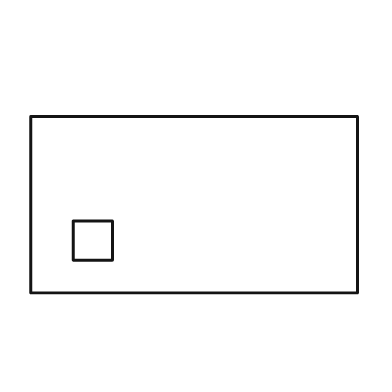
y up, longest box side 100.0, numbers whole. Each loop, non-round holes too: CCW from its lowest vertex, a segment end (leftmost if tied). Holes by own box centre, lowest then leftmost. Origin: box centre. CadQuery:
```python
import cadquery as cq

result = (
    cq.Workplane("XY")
    .moveTo(-50.0, -27.0)
    .lineTo(50.0, -27.0)
    .lineTo(50.0, 27.0)
    .lineTo(-50.0, 27.0)
    .close()
    .moveTo(-37.0, -17.0)
    .lineTo(-25.0, -17.0)
    .lineTo(-25.0, -5.0)
    .lineTo(-37.0, -5.0)
    .close()
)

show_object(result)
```